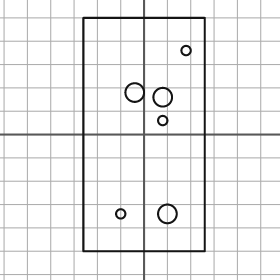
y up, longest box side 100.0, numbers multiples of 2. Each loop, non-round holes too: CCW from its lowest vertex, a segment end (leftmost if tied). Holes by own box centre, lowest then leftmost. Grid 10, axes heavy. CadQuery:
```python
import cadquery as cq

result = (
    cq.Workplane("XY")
    .moveTo(-26.0, -50.0)
    .lineTo(26.0, -50.0)
    .lineTo(26.0, 50.0)
    .lineTo(-26.0, 50.0)
    .close()
    .moveTo(-10.0, -34.0)
    .circle(2.0)
    .moveTo(10.0, -34.0)
    .circle(4.0)
    .moveTo(8.0, 6.0)
    .circle(2.0)
    .moveTo(8.0, 16.0)
    .circle(4.0)
    .moveTo(-4.0, 18.0)
    .circle(4.0)
    .moveTo(18.0, 36.0)
    .circle(2.0)
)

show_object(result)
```